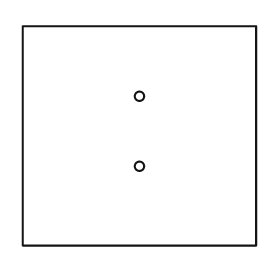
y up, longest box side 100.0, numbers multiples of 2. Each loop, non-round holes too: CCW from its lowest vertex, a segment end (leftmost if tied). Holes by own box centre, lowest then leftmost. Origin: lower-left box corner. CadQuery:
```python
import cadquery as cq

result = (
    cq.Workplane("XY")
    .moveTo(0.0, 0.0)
    .lineTo(100.0, 0.0)
    .lineTo(100.0, 94.0)
    .lineTo(0.0, 94.0)
    .close()
    .moveTo(50.0, 34.0)
    .circle(2.0)
    .moveTo(50.0, 64.0)
    .circle(2.0)
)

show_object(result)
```